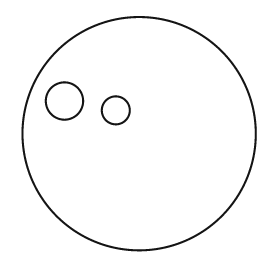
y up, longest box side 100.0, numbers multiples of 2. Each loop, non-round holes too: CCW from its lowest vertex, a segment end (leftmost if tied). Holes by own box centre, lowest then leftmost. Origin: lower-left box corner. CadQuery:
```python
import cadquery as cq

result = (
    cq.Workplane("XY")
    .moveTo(50.0, 50.0)
    .circle(50.0)
    .moveTo(40.0, 60.0)
    .circle(6.0)
    .moveTo(18.0, 64.0)
    .circle(8.0)
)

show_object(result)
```